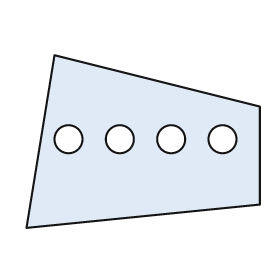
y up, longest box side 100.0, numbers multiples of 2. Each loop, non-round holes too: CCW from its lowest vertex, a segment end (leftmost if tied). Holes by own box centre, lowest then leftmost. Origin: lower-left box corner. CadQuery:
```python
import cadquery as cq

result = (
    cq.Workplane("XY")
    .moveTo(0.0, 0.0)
    .lineTo(100.0, 10.0)
    .lineTo(100.0, 52.0)
    .lineTo(12.0, 74.0)
    .close()
    .moveTo(18.0, 38.0)
    .circle(6.0)
    .moveTo(40.0, 38.0)
    .circle(6.0)
    .moveTo(62.0, 38.0)
    .circle(6.0)
    .moveTo(84.0, 38.0)
    .circle(6.0)
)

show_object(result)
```